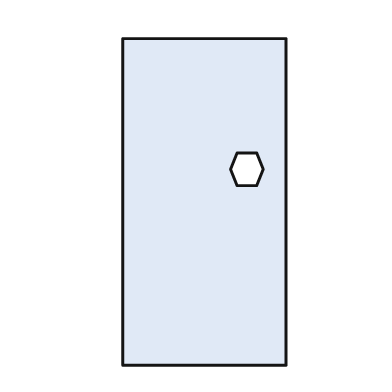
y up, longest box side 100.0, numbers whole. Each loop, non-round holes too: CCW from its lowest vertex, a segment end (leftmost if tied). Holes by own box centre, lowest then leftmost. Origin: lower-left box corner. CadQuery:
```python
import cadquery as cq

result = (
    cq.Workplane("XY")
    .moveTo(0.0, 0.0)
    .lineTo(50.0, 0.0)
    .lineTo(50.0, 100.0)
    .lineTo(0.0, 100.0)
    .close()
    .moveTo(35.0, 55.0)
    .lineTo(41.0, 55.0)
    .lineTo(43.0, 60.0)
    .lineTo(41.0, 65.0)
    .lineTo(35.0, 65.0)
    .lineTo(33.0, 60.0)
    .close()
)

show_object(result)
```